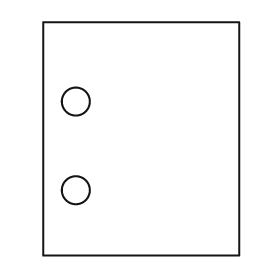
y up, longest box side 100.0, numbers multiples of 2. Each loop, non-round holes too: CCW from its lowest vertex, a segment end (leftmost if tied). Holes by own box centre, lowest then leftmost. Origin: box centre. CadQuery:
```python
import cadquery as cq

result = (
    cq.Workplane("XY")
    .moveTo(-42.0, -50.0)
    .lineTo(42.0, -50.0)
    .lineTo(42.0, 50.0)
    .lineTo(-42.0, 50.0)
    .close()
    .moveTo(-28.0, -22.0)
    .circle(6.0)
    .moveTo(-28.0, 16.0)
    .circle(6.0)
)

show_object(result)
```